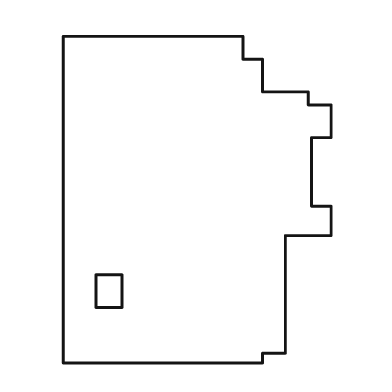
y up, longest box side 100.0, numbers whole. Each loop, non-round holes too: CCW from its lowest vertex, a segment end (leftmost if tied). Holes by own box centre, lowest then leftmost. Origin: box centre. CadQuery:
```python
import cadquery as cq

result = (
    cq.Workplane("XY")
    .moveTo(-41.0, -50.0)
    .lineTo(20.0, -50.0)
    .lineTo(20.0, -47.0)
    .lineTo(27.0, -47.0)
    .lineTo(27.0, -11.0)
    .lineTo(41.0, -11.0)
    .lineTo(41.0, -2.0)
    .lineTo(35.0, -2.0)
    .lineTo(35.0, 19.0)
    .lineTo(41.0, 19.0)
    .lineTo(41.0, 29.0)
    .lineTo(34.0, 29.0)
    .lineTo(34.0, 33.0)
    .lineTo(20.0, 33.0)
    .lineTo(20.0, 43.0)
    .lineTo(14.0, 43.0)
    .lineTo(14.0, 50.0)
    .lineTo(-41.0, 50.0)
    .close()
    .moveTo(-31.0, -33.0)
    .lineTo(-23.0, -33.0)
    .lineTo(-23.0, -23.0)
    .lineTo(-31.0, -23.0)
    .close()
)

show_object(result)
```